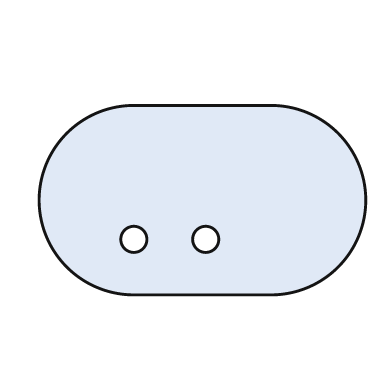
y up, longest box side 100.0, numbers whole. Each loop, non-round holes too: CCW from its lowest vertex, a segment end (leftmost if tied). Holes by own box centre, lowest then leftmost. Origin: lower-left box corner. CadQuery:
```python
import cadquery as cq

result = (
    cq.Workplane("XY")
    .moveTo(29.0, 0.0)
    .lineTo(71.0, 0.0)
    .threePointArc((100.0, 29.0), (71.0, 58.0))
    .lineTo(29.0, 58.0)
    .threePointArc((0.0, 29.0), (29.0, 0.0))
    .close()
    .moveTo(29.0, 17.0)
    .circle(4.0)
    .moveTo(51.0, 17.0)
    .circle(4.0)
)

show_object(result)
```